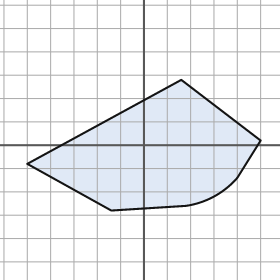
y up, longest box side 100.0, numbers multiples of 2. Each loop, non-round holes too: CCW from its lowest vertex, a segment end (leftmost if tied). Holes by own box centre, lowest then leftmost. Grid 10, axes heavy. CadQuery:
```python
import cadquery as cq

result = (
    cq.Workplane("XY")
    .moveTo(-14.0, -28.0)
    .lineTo(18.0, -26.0)
    .threePointArc((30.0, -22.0), (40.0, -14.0))
    .lineTo(50.0, 2.0)
    .lineTo(16.0, 28.0)
    .lineTo(-50.0, -8.0)
    .close()
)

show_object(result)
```